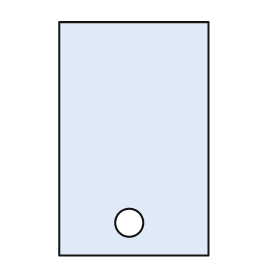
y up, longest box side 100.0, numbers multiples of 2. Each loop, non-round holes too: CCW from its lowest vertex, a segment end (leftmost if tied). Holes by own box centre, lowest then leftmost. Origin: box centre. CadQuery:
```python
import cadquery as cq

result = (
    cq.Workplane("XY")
    .moveTo(-32.0, -50.0)
    .lineTo(32.0, -50.0)
    .lineTo(32.0, 50.0)
    .lineTo(-32.0, 50.0)
    .close()
    .moveTo(-2.0, -36.0)
    .circle(6.0)
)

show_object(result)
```